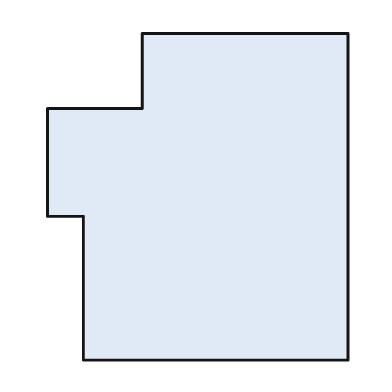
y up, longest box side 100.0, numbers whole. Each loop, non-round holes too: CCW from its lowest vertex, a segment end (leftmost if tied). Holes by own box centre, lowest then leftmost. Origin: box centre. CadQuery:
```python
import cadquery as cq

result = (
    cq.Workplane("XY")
    .moveTo(-35.0, -50.0)
    .lineTo(46.0, -50.0)
    .lineTo(46.0, 50.0)
    .lineTo(-17.0, 50.0)
    .lineTo(-17.0, 27.0)
    .lineTo(-46.0, 27.0)
    .lineTo(-46.0, -6.0)
    .lineTo(-35.0, -6.0)
    .close()
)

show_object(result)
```